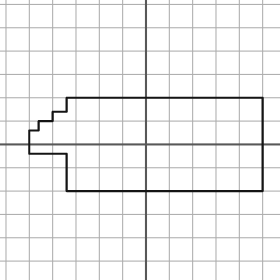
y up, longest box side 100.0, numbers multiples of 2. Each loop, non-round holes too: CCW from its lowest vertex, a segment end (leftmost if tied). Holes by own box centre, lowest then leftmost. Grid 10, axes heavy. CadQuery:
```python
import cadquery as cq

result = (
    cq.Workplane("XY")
    .moveTo(-34.0, -20.0)
    .lineTo(50.0, -20.0)
    .lineTo(50.0, 20.0)
    .lineTo(-34.0, 20.0)
    .lineTo(-34.0, 14.0)
    .lineTo(-40.0, 14.0)
    .lineTo(-40.0, 10.0)
    .lineTo(-46.0, 10.0)
    .lineTo(-46.0, 6.0)
    .lineTo(-50.0, 6.0)
    .lineTo(-50.0, -4.0)
    .lineTo(-34.0, -4.0)
    .close()
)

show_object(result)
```